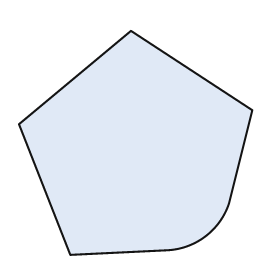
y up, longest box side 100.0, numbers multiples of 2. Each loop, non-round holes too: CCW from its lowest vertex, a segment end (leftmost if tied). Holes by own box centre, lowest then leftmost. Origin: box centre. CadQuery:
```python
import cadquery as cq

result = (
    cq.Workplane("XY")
    .moveTo(-28.0, -48.0)
    .lineTo(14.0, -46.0)
    .threePointArc((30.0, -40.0), (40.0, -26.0))
    .lineTo(50.0, 14.0)
    .lineTo(-2.0, 48.0)
    .lineTo(-50.0, 8.0)
    .close()
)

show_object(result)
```